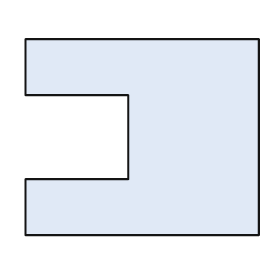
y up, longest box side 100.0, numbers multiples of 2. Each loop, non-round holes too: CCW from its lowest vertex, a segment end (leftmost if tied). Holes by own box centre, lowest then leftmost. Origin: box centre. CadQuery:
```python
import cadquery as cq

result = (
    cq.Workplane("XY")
    .moveTo(-50.0, -42.0)
    .lineTo(50.0, -42.0)
    .lineTo(50.0, 42.0)
    .lineTo(-50.0, 42.0)
    .lineTo(-50.0, 18.0)
    .lineTo(-6.0, 18.0)
    .lineTo(-6.0, -18.0)
    .lineTo(-50.0, -18.0)
    .close()
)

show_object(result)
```